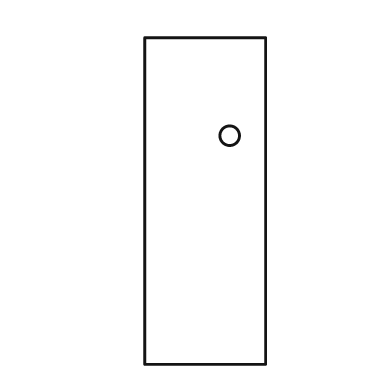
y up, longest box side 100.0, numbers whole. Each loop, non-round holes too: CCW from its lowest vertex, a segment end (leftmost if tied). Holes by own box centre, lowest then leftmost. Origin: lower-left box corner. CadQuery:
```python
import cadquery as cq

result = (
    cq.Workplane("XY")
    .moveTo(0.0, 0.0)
    .lineTo(37.0, 0.0)
    .lineTo(37.0, 100.0)
    .lineTo(0.0, 100.0)
    .close()
    .moveTo(26.0, 70.0)
    .circle(3.0)
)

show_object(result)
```